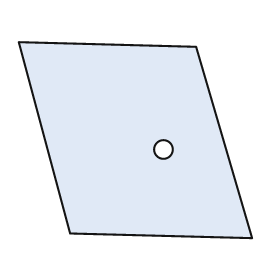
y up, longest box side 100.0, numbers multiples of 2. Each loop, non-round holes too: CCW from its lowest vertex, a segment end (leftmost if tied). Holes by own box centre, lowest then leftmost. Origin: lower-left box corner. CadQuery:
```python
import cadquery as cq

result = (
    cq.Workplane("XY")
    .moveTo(100.0, 0.0)
    .lineTo(76.0, 82.0)
    .lineTo(0.0, 84.0)
    .lineTo(22.0, 2.0)
    .close()
    .moveTo(62.0, 38.0)
    .circle(4.0)
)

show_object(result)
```